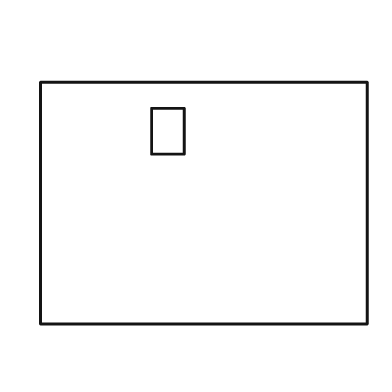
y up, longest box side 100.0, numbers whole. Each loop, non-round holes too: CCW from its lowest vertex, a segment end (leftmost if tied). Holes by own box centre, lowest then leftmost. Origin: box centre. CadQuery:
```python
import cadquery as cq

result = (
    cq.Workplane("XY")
    .moveTo(-50.0, -37.0)
    .lineTo(50.0, -37.0)
    .lineTo(50.0, 37.0)
    .lineTo(-50.0, 37.0)
    .close()
    .moveTo(-16.0, 15.0)
    .lineTo(-6.0, 15.0)
    .lineTo(-6.0, 29.0)
    .lineTo(-16.0, 29.0)
    .close()
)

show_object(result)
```